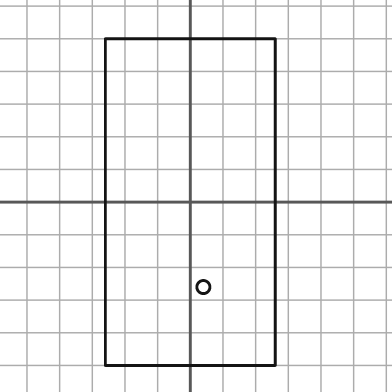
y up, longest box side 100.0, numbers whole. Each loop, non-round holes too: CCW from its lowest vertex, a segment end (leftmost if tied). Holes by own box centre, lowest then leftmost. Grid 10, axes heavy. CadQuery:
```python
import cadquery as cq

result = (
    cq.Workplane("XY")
    .moveTo(-26.0, -50.0)
    .lineTo(26.0, -50.0)
    .lineTo(26.0, 50.0)
    .lineTo(-26.0, 50.0)
    .close()
    .moveTo(4.0, -26.0)
    .circle(2.0)
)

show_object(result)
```